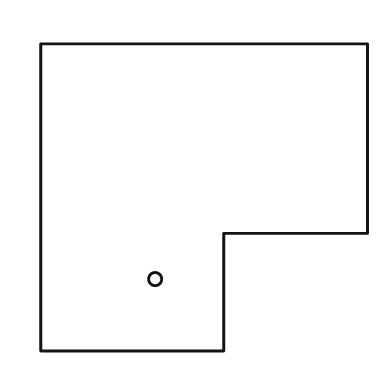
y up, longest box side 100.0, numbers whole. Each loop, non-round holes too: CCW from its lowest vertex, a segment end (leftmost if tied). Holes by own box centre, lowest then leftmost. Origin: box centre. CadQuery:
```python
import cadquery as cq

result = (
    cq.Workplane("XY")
    .moveTo(-50.0, -47.0)
    .lineTo(6.0, -47.0)
    .lineTo(6.0, -11.0)
    .lineTo(50.0, -11.0)
    .lineTo(50.0, 47.0)
    .lineTo(-50.0, 47.0)
    .close()
    .moveTo(-15.0, -25.0)
    .circle(2.0)
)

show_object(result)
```